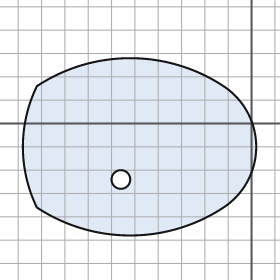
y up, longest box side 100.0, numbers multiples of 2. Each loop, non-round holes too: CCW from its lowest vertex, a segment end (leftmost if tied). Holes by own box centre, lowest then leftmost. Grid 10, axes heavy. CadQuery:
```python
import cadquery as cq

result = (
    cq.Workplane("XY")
    .moveTo(-92.0, -36.0)
    .threePointArc((-52.0, -48.0), (-12.0, -36.0))
    .threePointArc((2.0, -10.0), (-12.0, 16.0))
    .threePointArc((-52.0, 28.0), (-92.0, 16.0))
    .threePointArc((-98.0, -10.0), (-92.0, -36.0))
    .close()
    .moveTo(-56.0, -24.0)
    .circle(4.0)
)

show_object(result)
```